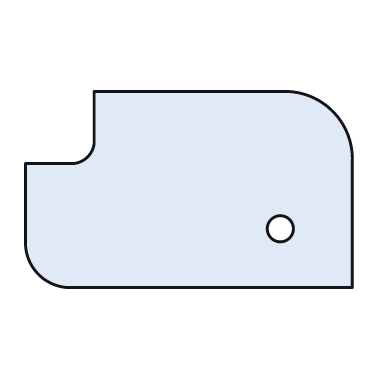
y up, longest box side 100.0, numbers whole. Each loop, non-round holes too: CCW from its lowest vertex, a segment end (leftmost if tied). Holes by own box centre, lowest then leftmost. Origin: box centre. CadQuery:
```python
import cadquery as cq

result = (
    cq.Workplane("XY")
    .moveTo(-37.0, -30.0)
    .lineTo(50.0, -30.0)
    .lineTo(50.0, 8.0)
    .threePointArc((44.0, 24.0), (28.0, 30.0))
    .lineTo(-29.0, 30.0)
    .lineTo(-29.0, 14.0)
    .threePointArc((-31.0, 10.0), (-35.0, 8.0))
    .lineTo(-50.0, 8.0)
    .lineTo(-50.0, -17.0)
    .threePointArc((-46.0, -26.0), (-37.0, -30.0))
    .close()
    .moveTo(28.0, -12.0)
    .circle(4.0)
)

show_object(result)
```